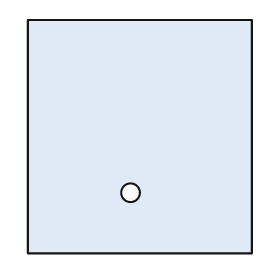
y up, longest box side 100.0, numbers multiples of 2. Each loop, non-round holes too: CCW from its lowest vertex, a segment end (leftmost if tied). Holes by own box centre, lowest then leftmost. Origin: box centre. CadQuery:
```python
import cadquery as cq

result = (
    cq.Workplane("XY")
    .moveTo(-48.0, -50.0)
    .lineTo(48.0, -50.0)
    .lineTo(48.0, 50.0)
    .lineTo(-48.0, 50.0)
    .close()
    .moveTo(-4.0, -24.0)
    .circle(4.0)
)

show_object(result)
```